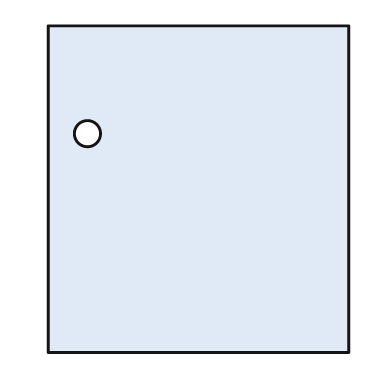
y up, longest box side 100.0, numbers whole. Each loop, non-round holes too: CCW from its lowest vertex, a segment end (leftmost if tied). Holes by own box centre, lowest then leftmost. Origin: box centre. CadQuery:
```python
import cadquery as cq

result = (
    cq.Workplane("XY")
    .moveTo(-46.0, -50.0)
    .lineTo(46.0, -50.0)
    .lineTo(46.0, 50.0)
    .lineTo(-46.0, 50.0)
    .close()
    .moveTo(-34.0, 17.0)
    .circle(4.0)
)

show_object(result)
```